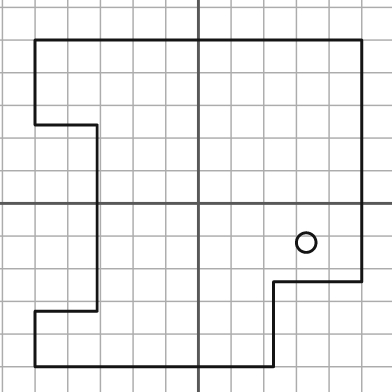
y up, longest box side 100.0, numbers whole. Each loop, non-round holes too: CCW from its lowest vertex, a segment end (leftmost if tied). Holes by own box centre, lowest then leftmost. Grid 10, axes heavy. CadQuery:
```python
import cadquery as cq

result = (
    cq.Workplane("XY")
    .moveTo(-50.0, -50.0)
    .lineTo(23.0, -50.0)
    .lineTo(23.0, -24.0)
    .lineTo(50.0, -24.0)
    .lineTo(50.0, 50.0)
    .lineTo(-50.0, 50.0)
    .lineTo(-50.0, 24.0)
    .lineTo(-31.0, 24.0)
    .lineTo(-31.0, -33.0)
    .lineTo(-50.0, -33.0)
    .close()
    .moveTo(33.0, -12.0)
    .circle(3.0)
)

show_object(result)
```